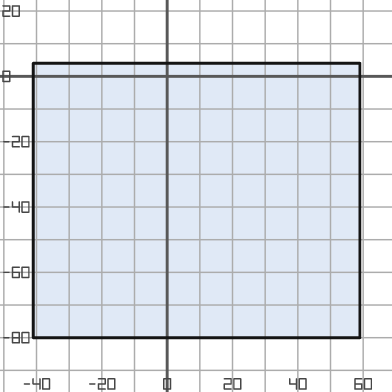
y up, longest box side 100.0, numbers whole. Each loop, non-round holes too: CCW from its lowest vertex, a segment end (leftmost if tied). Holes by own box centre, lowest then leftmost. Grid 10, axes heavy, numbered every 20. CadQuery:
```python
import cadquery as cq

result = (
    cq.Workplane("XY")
    .moveTo(-41.0, -80.0)
    .lineTo(59.0, -80.0)
    .lineTo(59.0, 4.0)
    .lineTo(-41.0, 4.0)
    .close()
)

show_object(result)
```